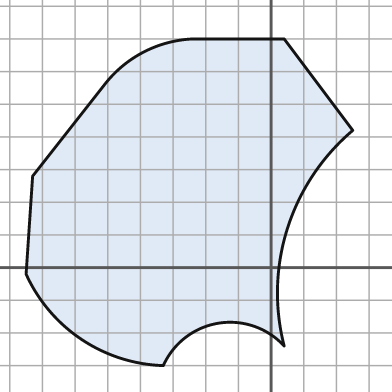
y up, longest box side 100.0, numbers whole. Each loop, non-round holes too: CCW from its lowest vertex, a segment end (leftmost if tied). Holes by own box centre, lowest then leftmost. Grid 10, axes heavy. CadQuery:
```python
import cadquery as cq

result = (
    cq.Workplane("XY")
    .moveTo(-33.0, -30.0)
    .threePointArc((-16.0, -17.0), (4.0, -24.0))
    .threePointArc((5.0, 12.0), (25.0, 42.0))
    .lineTo(4.0, 70.0)
    .lineTo(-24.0, 70.0)
    .threePointArc((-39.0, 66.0), (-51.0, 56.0))
    .lineTo(-73.0, 28.0)
    .lineTo(-75.0, -2.0)
    .threePointArc((-58.0, -22.0), (-33.0, -30.0))
    .close()
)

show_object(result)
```